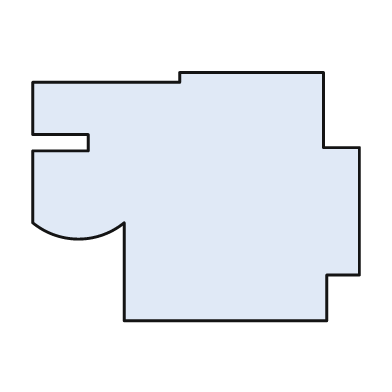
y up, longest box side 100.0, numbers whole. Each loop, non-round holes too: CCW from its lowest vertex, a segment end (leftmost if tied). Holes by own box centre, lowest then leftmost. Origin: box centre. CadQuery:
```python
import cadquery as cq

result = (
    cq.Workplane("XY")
    .moveTo(-22.0, -38.0)
    .lineTo(40.0, -38.0)
    .lineTo(40.0, -24.0)
    .lineTo(50.0, -24.0)
    .lineTo(50.0, 15.0)
    .lineTo(39.0, 15.0)
    .lineTo(39.0, 38.0)
    .lineTo(-5.0, 38.0)
    .lineTo(-5.0, 35.0)
    .lineTo(-50.0, 35.0)
    .lineTo(-50.0, 19.0)
    .lineTo(-33.0, 19.0)
    .lineTo(-33.0, 14.0)
    .lineTo(-50.0, 14.0)
    .lineTo(-50.0, -8.0)
    .threePointArc((-36.0, -13.0), (-22.0, -8.0))
    .close()
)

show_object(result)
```